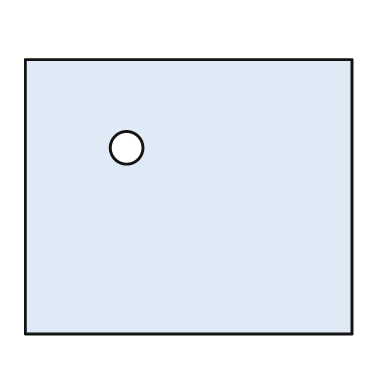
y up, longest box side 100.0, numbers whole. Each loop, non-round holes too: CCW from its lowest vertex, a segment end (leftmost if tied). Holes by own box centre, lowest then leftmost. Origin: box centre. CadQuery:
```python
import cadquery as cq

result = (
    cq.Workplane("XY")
    .moveTo(-50.0, -42.0)
    .lineTo(50.0, -42.0)
    .lineTo(50.0, 42.0)
    .lineTo(-50.0, 42.0)
    .close()
    .moveTo(-19.0, 15.0)
    .circle(5.0)
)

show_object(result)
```